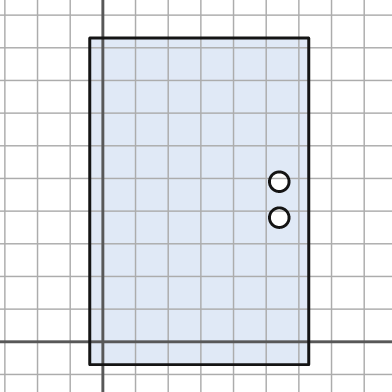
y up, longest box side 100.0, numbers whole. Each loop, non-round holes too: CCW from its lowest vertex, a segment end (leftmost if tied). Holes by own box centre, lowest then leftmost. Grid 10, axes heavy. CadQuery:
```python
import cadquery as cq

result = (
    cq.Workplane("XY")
    .moveTo(-4.0, -7.0)
    .lineTo(63.0, -7.0)
    .lineTo(63.0, 93.0)
    .lineTo(-4.0, 93.0)
    .close()
    .moveTo(54.0, 38.0)
    .circle(3.0)
    .moveTo(54.0, 49.0)
    .circle(3.0)
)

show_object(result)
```